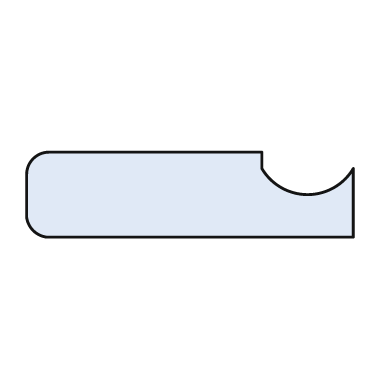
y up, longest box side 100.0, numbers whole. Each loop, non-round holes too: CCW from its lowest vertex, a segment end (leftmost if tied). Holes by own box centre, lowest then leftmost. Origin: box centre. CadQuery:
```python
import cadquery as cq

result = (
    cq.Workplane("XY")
    .moveTo(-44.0, -13.0)
    .lineTo(50.0, -13.0)
    .lineTo(50.0, 8.0)
    .threePointArc((36.0, 0.0), (22.0, 8.0))
    .lineTo(22.0, 13.0)
    .lineTo(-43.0, 13.0)
    .threePointArc((-48.0, 11.0), (-50.0, 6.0))
    .lineTo(-50.0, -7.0)
    .threePointArc((-48.0, -11.0), (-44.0, -13.0))
    .close()
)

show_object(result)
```